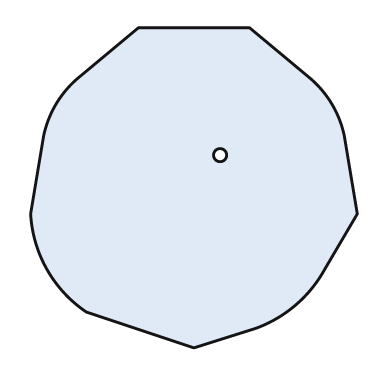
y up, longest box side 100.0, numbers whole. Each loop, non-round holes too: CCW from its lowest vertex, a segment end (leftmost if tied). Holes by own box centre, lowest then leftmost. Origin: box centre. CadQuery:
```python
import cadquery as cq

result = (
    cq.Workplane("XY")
    .moveTo(0.0, -49.0)
    .lineTo(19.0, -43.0)
    .threePointArc((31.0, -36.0), (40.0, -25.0))
    .lineTo(50.0, -8.0)
    .lineTo(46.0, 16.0)
    .threePointArc((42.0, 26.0), (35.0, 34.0))
    .lineTo(17.0, 49.0)
    .lineTo(-17.0, 49.0)
    .lineTo(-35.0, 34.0)
    .threePointArc((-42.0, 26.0), (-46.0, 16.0))
    .lineTo(-50.0, -8.0)
    .threePointArc((-45.0, -25.0), (-33.0, -38.0))
    .close()
    .moveTo(8.0, 10.0)
    .circle(2.0)
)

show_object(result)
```